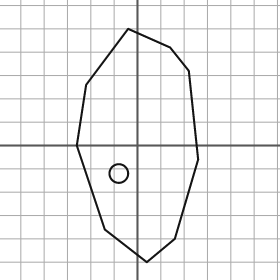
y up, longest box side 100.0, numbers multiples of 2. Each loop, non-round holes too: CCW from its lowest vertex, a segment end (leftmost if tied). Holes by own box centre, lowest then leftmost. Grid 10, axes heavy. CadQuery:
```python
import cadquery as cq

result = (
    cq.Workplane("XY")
    .moveTo(4.0, -50.0)
    .lineTo(16.0, -40.0)
    .lineTo(26.0, -6.0)
    .lineTo(22.0, 32.0)
    .lineTo(14.0, 42.0)
    .lineTo(-4.0, 50.0)
    .lineTo(-22.0, 26.0)
    .lineTo(-26.0, 0.0)
    .lineTo(-14.0, -36.0)
    .close()
    .moveTo(-8.0, -12.0)
    .circle(4.0)
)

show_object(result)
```